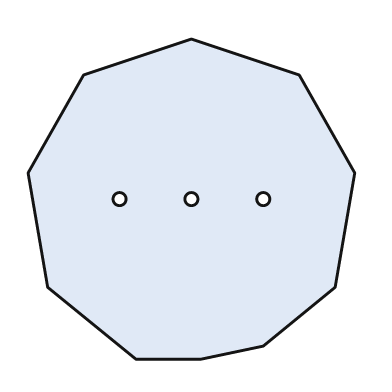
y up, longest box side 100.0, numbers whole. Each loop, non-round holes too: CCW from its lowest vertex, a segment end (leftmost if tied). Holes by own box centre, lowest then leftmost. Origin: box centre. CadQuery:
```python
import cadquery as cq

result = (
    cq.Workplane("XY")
    .moveTo(-17.0, -49.0)
    .lineTo(3.0, -49.0)
    .lineTo(22.0, -45.0)
    .lineTo(44.0, -27.0)
    .lineTo(50.0, 8.0)
    .lineTo(33.0, 38.0)
    .lineTo(0.0, 49.0)
    .lineTo(-33.0, 38.0)
    .lineTo(-50.0, 8.0)
    .lineTo(-44.0, -27.0)
    .close()
    .moveTo(-22.0, 0.0)
    .circle(2.0)
    .moveTo(0.0, 0.0)
    .circle(2.0)
    .moveTo(22.0, 0.0)
    .circle(2.0)
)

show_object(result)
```